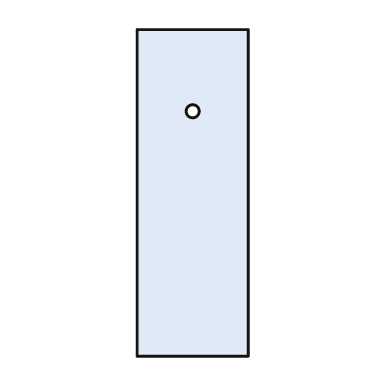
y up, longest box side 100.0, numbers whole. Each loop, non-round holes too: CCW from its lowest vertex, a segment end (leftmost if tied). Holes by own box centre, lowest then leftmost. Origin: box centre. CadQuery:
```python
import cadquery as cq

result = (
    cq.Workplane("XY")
    .moveTo(-17.0, -50.0)
    .lineTo(17.0, -50.0)
    .lineTo(17.0, 50.0)
    .lineTo(-17.0, 50.0)
    .close()
    .moveTo(0.0, 25.0)
    .circle(2.0)
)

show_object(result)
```